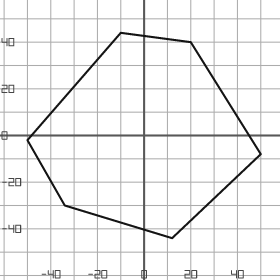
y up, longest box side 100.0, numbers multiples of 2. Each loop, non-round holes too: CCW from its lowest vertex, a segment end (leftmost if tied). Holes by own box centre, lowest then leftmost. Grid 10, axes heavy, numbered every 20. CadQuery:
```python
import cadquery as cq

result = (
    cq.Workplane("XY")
    .moveTo(12.0, -44.0)
    .lineTo(50.0, -8.0)
    .lineTo(20.0, 40.0)
    .lineTo(-10.0, 44.0)
    .lineTo(-50.0, -2.0)
    .lineTo(-34.0, -30.0)
    .close()
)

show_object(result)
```